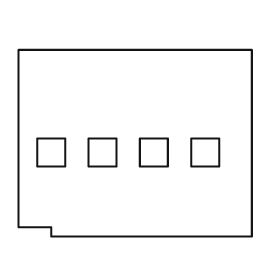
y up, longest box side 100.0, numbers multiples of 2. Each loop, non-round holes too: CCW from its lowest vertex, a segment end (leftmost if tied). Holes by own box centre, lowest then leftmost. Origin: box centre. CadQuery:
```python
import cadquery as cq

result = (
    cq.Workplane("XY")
    .moveTo(-36.0, -40.0)
    .lineTo(50.0, -40.0)
    .lineTo(50.0, 40.0)
    .lineTo(-50.0, 40.0)
    .lineTo(-50.0, -36.0)
    .lineTo(-36.0, -36.0)
    .close()
    .moveTo(-42.0, -10.0)
    .lineTo(-30.0, -10.0)
    .lineTo(-30.0, 2.0)
    .lineTo(-42.0, 2.0)
    .close()
    .moveTo(-20.0, -10.0)
    .lineTo(-8.0, -10.0)
    .lineTo(-8.0, 2.0)
    .lineTo(-20.0, 2.0)
    .close()
    .moveTo(2.0, -10.0)
    .lineTo(14.0, -10.0)
    .lineTo(14.0, 2.0)
    .lineTo(2.0, 2.0)
    .close()
    .moveTo(24.0, -10.0)
    .lineTo(36.0, -10.0)
    .lineTo(36.0, 2.0)
    .lineTo(24.0, 2.0)
    .close()
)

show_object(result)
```